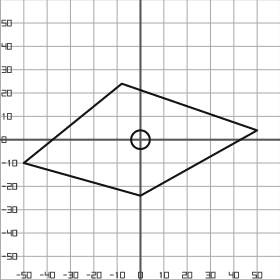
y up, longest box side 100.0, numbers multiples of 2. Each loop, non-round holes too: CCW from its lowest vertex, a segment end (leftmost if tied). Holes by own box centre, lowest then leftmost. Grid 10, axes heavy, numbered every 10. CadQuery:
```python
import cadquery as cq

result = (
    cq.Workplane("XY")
    .moveTo(0.0, -24.0)
    .lineTo(50.0, 4.0)
    .lineTo(-8.0, 24.0)
    .lineTo(-50.0, -10.0)
    .close()
    .moveTo(0.0, 0.0)
    .circle(4.0)
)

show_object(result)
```